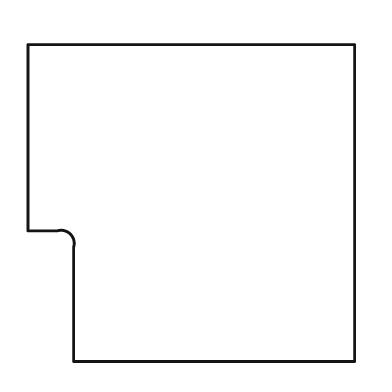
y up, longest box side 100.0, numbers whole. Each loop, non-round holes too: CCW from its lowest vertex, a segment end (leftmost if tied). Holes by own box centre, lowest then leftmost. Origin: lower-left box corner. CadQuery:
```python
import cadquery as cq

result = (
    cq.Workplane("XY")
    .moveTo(14.0, 0.0)
    .lineTo(100.0, 0.0)
    .lineTo(100.0, 97.0)
    .lineTo(0.0, 97.0)
    .lineTo(0.0, 40.0)
    .lineTo(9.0, 40.0)
    .threePointArc((13.0, 39.0), (14.0, 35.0))
    .close()
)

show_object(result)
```